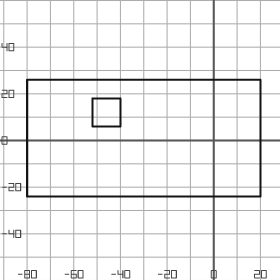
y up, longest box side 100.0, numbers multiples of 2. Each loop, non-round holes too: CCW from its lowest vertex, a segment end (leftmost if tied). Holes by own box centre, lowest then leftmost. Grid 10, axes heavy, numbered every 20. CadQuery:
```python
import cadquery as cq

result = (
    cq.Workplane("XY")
    .moveTo(-80.0, -24.0)
    .lineTo(20.0, -24.0)
    .lineTo(20.0, 26.0)
    .lineTo(-80.0, 26.0)
    .close()
    .moveTo(-52.0, 6.0)
    .lineTo(-40.0, 6.0)
    .lineTo(-40.0, 18.0)
    .lineTo(-52.0, 18.0)
    .close()
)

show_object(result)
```